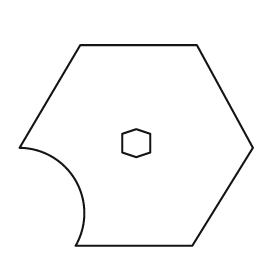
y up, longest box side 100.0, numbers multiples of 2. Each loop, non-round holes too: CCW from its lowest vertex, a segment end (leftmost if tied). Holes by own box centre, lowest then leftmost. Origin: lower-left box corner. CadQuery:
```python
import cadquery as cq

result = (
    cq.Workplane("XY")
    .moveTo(24.0, 0.0)
    .lineTo(74.0, 0.0)
    .lineTo(100.0, 42.0)
    .lineTo(76.0, 86.0)
    .lineTo(26.0, 86.0)
    .lineTo(0.0, 42.0)
    .threePointArc((24.0, 28.0), (24.0, 0.0))
    .close()
    .moveTo(50.0, 38.0)
    .lineTo(56.0, 40.0)
    .lineTo(56.0, 48.0)
    .lineTo(50.0, 50.0)
    .lineTo(44.0, 48.0)
    .lineTo(44.0, 40.0)
    .close()
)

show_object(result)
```